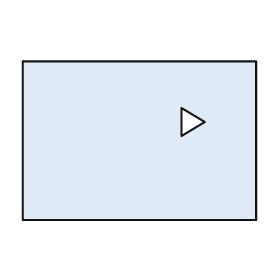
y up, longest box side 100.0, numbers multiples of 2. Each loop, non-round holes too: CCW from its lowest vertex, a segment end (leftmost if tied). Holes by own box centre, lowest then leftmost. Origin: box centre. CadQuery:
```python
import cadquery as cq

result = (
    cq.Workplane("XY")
    .moveTo(-50.0, -34.0)
    .lineTo(50.0, -34.0)
    .lineTo(50.0, 34.0)
    .lineTo(-50.0, 34.0)
    .close()
    .moveTo(18.0, 2.0)
    .lineTo(28.0, 8.0)
    .lineTo(18.0, 14.0)
    .close()
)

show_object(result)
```